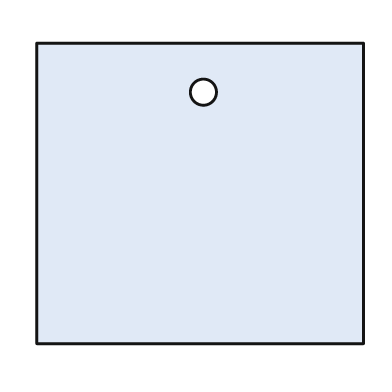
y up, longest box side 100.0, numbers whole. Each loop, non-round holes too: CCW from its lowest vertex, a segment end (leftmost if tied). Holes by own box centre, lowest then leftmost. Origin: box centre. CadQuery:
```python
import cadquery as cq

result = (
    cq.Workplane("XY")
    .moveTo(-50.0, -46.0)
    .lineTo(50.0, -46.0)
    .lineTo(50.0, 46.0)
    .lineTo(-50.0, 46.0)
    .close()
    .moveTo(1.0, 31.0)
    .circle(4.0)
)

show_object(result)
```